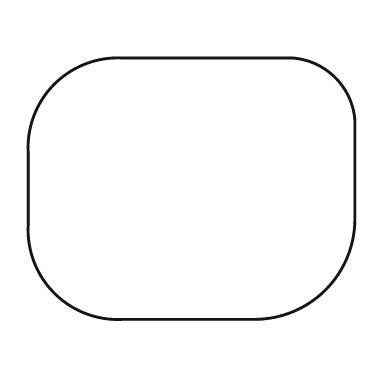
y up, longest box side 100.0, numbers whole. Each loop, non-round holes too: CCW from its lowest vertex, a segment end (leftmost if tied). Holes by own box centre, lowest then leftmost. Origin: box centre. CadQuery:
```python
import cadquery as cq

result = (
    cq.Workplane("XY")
    .moveTo(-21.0, -40.0)
    .lineTo(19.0, -40.0)
    .threePointArc((41.0, -31.0), (50.0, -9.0))
    .lineTo(50.0, 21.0)
    .threePointArc((44.0, 34.0), (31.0, 40.0))
    .lineTo(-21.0, 40.0)
    .threePointArc((-42.0, 32.0), (-50.0, 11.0))
    .lineTo(-50.0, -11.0)
    .threePointArc((-42.0, -32.0), (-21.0, -40.0))
    .close()
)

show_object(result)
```